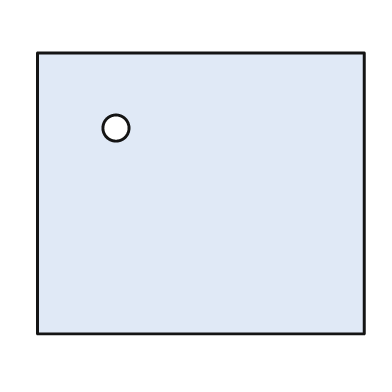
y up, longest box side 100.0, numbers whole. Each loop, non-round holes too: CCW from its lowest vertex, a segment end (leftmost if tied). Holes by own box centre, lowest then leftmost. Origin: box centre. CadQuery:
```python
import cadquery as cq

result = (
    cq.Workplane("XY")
    .moveTo(-50.0, -43.0)
    .lineTo(50.0, -43.0)
    .lineTo(50.0, 43.0)
    .lineTo(-50.0, 43.0)
    .close()
    .moveTo(-26.0, 20.0)
    .circle(4.0)
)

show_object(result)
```